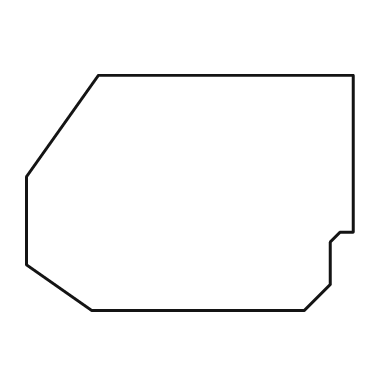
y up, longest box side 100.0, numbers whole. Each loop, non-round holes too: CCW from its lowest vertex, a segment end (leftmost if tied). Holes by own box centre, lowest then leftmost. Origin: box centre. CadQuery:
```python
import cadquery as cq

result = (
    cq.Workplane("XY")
    .moveTo(-30.0, -36.0)
    .lineTo(35.0, -36.0)
    .lineTo(43.0, -28.0)
    .lineTo(43.0, -15.0)
    .lineTo(46.0, -12.0)
    .lineTo(50.0, -12.0)
    .lineTo(50.0, 36.0)
    .lineTo(-28.0, 36.0)
    .lineTo(-50.0, 5.0)
    .lineTo(-50.0, -22.0)
    .close()
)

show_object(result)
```